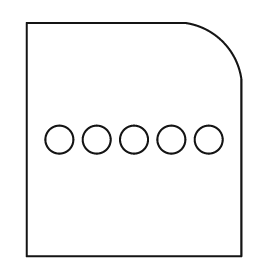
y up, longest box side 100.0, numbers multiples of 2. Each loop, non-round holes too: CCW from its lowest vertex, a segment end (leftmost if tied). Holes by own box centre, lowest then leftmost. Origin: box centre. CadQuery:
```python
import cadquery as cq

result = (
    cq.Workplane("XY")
    .moveTo(-46.0, -50.0)
    .lineTo(46.0, -50.0)
    .lineTo(46.0, 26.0)
    .threePointArc((38.0, 42.0), (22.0, 50.0))
    .lineTo(-46.0, 50.0)
    .close()
    .moveTo(-32.0, 0.0)
    .circle(6.0)
    .moveTo(-16.0, 0.0)
    .circle(6.0)
    .moveTo(0.0, 0.0)
    .circle(6.0)
    .moveTo(16.0, 0.0)
    .circle(6.0)
    .moveTo(32.0, 0.0)
    .circle(6.0)
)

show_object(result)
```